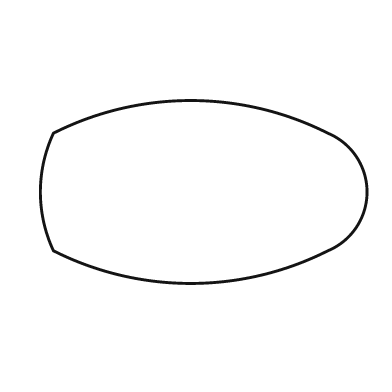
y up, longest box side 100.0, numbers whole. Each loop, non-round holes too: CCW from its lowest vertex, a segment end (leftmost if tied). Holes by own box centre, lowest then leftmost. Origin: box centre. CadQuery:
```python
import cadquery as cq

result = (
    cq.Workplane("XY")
    .moveTo(-46.0, -18.0)
    .threePointArc((-4.0, -28.0), (38.0, -18.0))
    .threePointArc((50.0, 0.0), (38.0, 18.0))
    .threePointArc((-4.0, 28.0), (-46.0, 18.0))
    .threePointArc((-50.0, 0.0), (-46.0, -18.0))
    .close()
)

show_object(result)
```